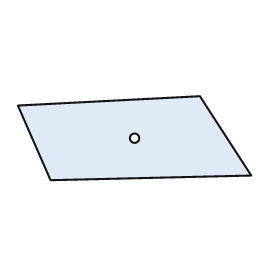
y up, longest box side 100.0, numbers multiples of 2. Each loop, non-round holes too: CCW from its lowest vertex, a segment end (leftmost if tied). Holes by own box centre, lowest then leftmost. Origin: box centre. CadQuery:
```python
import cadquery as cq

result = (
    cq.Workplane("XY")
    .moveTo(-36.0, -18.0)
    .lineTo(50.0, -16.0)
    .lineTo(28.0, 18.0)
    .lineTo(-50.0, 14.0)
    .close()
    .moveTo(0.0, 0.0)
    .circle(2.0)
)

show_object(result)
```